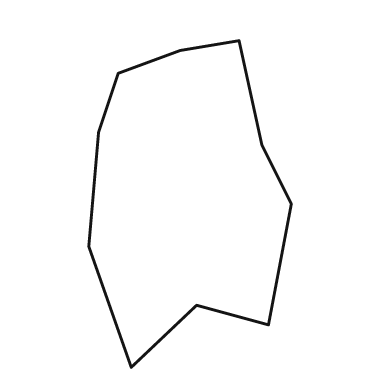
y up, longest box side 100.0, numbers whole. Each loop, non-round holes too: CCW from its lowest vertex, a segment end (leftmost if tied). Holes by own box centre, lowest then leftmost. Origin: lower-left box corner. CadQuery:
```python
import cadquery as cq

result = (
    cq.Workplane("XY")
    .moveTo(13.0, 0.0)
    .lineTo(33.0, 19.0)
    .lineTo(55.0, 13.0)
    .lineTo(62.0, 50.0)
    .lineTo(53.0, 68.0)
    .lineTo(46.0, 100.0)
    .lineTo(28.0, 97.0)
    .lineTo(9.0, 90.0)
    .lineTo(3.0, 72.0)
    .lineTo(0.0, 37.0)
    .close()
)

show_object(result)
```